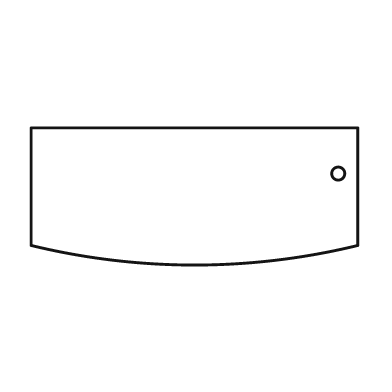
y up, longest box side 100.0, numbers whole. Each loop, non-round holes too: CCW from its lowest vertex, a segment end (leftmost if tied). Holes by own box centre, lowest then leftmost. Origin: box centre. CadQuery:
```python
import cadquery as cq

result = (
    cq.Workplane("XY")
    .moveTo(-50.0, -15.0)
    .threePointArc((0.0, -21.0), (50.0, -15.0))
    .lineTo(50.0, 21.0)
    .lineTo(-50.0, 21.0)
    .close()
    .moveTo(44.0, 7.0)
    .circle(2.0)
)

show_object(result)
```